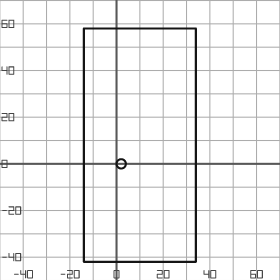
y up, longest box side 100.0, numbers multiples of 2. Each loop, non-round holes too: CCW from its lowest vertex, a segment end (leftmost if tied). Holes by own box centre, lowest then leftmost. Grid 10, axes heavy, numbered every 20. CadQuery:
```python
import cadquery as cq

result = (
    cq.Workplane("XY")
    .moveTo(-14.0, -42.0)
    .lineTo(34.0, -42.0)
    .lineTo(34.0, 58.0)
    .lineTo(-14.0, 58.0)
    .close()
    .moveTo(2.0, 0.0)
    .circle(2.0)
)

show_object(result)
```